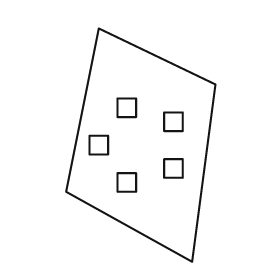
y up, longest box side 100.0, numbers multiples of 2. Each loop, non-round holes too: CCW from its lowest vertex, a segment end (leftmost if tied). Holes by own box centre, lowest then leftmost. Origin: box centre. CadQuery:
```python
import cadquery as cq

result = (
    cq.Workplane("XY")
    .moveTo(22.0, -50.0)
    .lineTo(32.0, 26.0)
    .lineTo(-18.0, 50.0)
    .lineTo(-32.0, -20.0)
    .close()
    .moveTo(-10.0, -20.0)
    .lineTo(-2.0, -20.0)
    .lineTo(-2.0, -12.0)
    .lineTo(-10.0, -12.0)
    .close()
    .moveTo(10.0, -14.0)
    .lineTo(18.0, -14.0)
    .lineTo(18.0, -6.0)
    .lineTo(10.0, -6.0)
    .close()
    .moveTo(-22.0, -4.0)
    .lineTo(-14.0, -4.0)
    .lineTo(-14.0, 4.0)
    .lineTo(-22.0, 4.0)
    .close()
    .moveTo(10.0, 6.0)
    .lineTo(18.0, 6.0)
    .lineTo(18.0, 14.0)
    .lineTo(10.0, 14.0)
    .close()
    .moveTo(-10.0, 12.0)
    .lineTo(-2.0, 12.0)
    .lineTo(-2.0, 20.0)
    .lineTo(-10.0, 20.0)
    .close()
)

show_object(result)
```